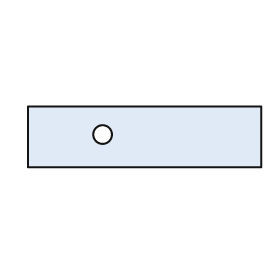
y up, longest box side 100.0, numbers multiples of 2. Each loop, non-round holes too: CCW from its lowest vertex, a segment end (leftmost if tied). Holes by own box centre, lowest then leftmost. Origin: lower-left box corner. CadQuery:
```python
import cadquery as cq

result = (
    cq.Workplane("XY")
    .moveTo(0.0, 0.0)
    .lineTo(100.0, 0.0)
    .lineTo(100.0, 26.0)
    .lineTo(0.0, 26.0)
    .close()
    .moveTo(32.0, 14.0)
    .circle(4.0)
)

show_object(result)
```